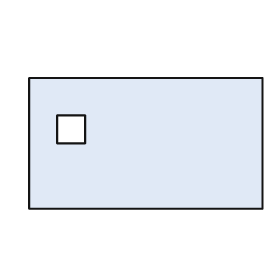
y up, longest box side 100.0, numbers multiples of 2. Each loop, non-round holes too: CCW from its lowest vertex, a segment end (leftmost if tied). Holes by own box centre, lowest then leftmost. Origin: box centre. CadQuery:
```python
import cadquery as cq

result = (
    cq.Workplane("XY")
    .moveTo(-50.0, -28.0)
    .lineTo(50.0, -28.0)
    .lineTo(50.0, 28.0)
    .lineTo(-50.0, 28.0)
    .close()
    .moveTo(-38.0, 0.0)
    .lineTo(-26.0, 0.0)
    .lineTo(-26.0, 12.0)
    .lineTo(-38.0, 12.0)
    .close()
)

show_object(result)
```